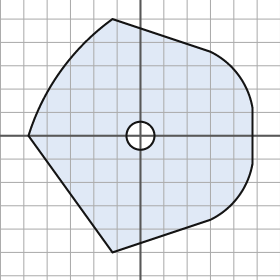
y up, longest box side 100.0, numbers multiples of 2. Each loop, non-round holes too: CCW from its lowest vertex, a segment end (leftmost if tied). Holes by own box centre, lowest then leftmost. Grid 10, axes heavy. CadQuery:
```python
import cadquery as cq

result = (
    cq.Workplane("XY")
    .moveTo(-12.0, -50.0)
    .lineTo(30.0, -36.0)
    .threePointArc((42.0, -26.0), (48.0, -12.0))
    .lineTo(48.0, 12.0)
    .threePointArc((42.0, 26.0), (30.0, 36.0))
    .lineTo(-12.0, 50.0)
    .threePointArc((-34.0, 28.0), (-48.0, 0.0))
    .close()
    .moveTo(0.0, 0.0)
    .circle(6.0)
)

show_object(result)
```